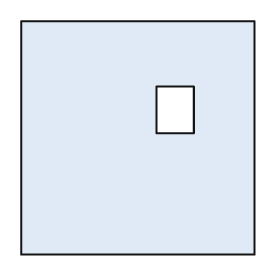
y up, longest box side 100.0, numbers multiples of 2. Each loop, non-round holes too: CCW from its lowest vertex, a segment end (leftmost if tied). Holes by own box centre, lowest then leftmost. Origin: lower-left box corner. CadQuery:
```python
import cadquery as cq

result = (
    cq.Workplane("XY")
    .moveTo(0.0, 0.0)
    .lineTo(100.0, 0.0)
    .lineTo(100.0, 100.0)
    .lineTo(0.0, 100.0)
    .close()
    .moveTo(58.0, 52.0)
    .lineTo(74.0, 52.0)
    .lineTo(74.0, 72.0)
    .lineTo(58.0, 72.0)
    .close()
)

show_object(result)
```